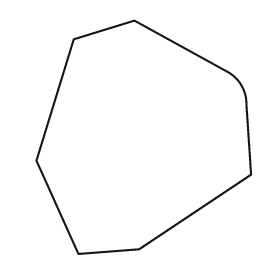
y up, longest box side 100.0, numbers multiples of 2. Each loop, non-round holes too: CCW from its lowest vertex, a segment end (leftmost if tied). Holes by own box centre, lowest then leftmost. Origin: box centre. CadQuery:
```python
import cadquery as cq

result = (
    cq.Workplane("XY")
    .moveTo(-28.0, -50.0)
    .lineTo(-2.0, -48.0)
    .lineTo(46.0, -16.0)
    .lineTo(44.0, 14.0)
    .threePointArc((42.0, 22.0), (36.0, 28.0))
    .lineTo(-4.0, 50.0)
    .lineTo(-30.0, 42.0)
    .lineTo(-46.0, -10.0)
    .close()
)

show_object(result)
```